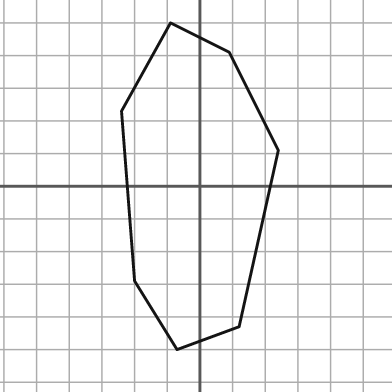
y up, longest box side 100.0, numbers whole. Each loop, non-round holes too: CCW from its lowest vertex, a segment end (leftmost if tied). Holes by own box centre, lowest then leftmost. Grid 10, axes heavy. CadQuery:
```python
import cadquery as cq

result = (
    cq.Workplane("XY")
    .moveTo(-7.0, -50.0)
    .lineTo(12.0, -43.0)
    .lineTo(24.0, 11.0)
    .lineTo(9.0, 41.0)
    .lineTo(-9.0, 50.0)
    .lineTo(-24.0, 23.0)
    .lineTo(-20.0, -29.0)
    .close()
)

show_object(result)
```